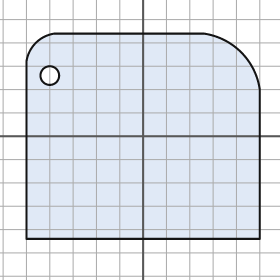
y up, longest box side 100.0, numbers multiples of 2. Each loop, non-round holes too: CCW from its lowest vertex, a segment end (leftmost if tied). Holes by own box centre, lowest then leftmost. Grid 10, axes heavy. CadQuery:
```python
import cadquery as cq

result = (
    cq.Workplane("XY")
    .moveTo(-50.0, -44.0)
    .lineTo(50.0, -44.0)
    .lineTo(50.0, 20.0)
    .threePointArc((42.0, 36.0), (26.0, 44.0))
    .lineTo(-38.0, 44.0)
    .threePointArc((-46.0, 40.0), (-50.0, 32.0))
    .close()
    .moveTo(-40.0, 26.0)
    .circle(4.0)
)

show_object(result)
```